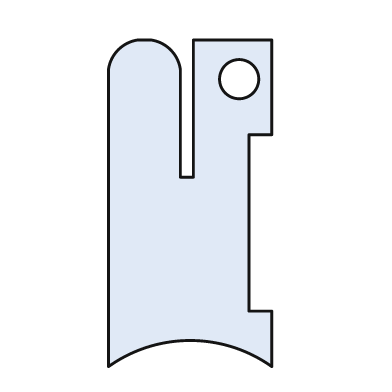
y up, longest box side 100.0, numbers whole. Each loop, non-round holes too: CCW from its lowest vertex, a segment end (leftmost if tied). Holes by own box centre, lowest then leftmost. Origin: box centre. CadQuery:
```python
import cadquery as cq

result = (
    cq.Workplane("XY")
    .moveTo(-25.0, -50.0)
    .threePointArc((0.0, -42.0), (25.0, -50.0))
    .lineTo(25.0, -33.0)
    .lineTo(18.0, -33.0)
    .lineTo(18.0, 21.0)
    .lineTo(25.0, 21.0)
    .lineTo(25.0, 50.0)
    .lineTo(1.0, 50.0)
    .lineTo(1.0, 8.0)
    .lineTo(-3.0, 8.0)
    .lineTo(-3.0, 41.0)
    .threePointArc((-6.0, 47.0), (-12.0, 50.0))
    .lineTo(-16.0, 50.0)
    .threePointArc((-22.0, 47.0), (-25.0, 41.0))
    .close()
    .moveTo(15.0, 38.0)
    .circle(6.0)
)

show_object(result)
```